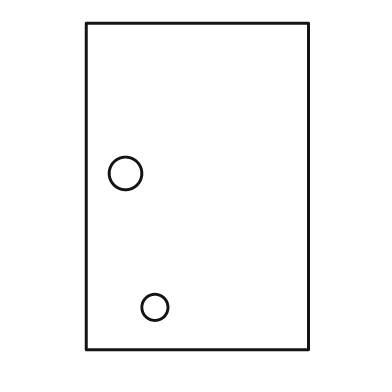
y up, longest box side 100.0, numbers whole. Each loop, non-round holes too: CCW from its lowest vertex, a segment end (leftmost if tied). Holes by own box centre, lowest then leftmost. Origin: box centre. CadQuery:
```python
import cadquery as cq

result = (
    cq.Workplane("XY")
    .moveTo(-34.0, -50.0)
    .lineTo(34.0, -50.0)
    .lineTo(34.0, 50.0)
    .lineTo(-34.0, 50.0)
    .close()
    .moveTo(-13.0, -37.0)
    .circle(4.0)
    .moveTo(-22.0, 4.0)
    .circle(5.0)
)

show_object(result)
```